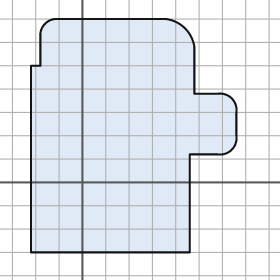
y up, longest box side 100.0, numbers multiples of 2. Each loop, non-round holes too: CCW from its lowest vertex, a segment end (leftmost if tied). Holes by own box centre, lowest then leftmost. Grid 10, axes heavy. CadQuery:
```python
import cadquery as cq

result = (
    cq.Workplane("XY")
    .moveTo(-22.0, -30.0)
    .lineTo(46.0, -30.0)
    .lineTo(46.0, 12.0)
    .lineTo(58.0, 12.0)
    .threePointArc((64.0, 14.0), (66.0, 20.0))
    .lineTo(66.0, 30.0)
    .threePointArc((64.0, 36.0), (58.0, 38.0))
    .lineTo(48.0, 38.0)
    .lineTo(48.0, 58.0)
    .threePointArc((44.0, 66.0), (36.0, 70.0))
    .lineTo(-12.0, 70.0)
    .threePointArc((-16.0, 68.0), (-18.0, 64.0))
    .lineTo(-18.0, 50.0)
    .lineTo(-22.0, 50.0)
    .close()
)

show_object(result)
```